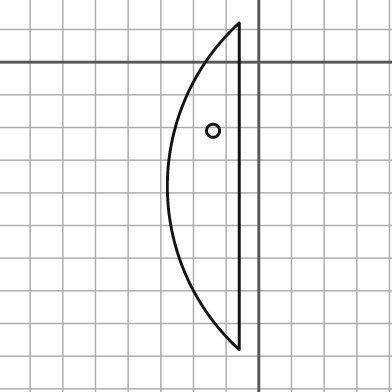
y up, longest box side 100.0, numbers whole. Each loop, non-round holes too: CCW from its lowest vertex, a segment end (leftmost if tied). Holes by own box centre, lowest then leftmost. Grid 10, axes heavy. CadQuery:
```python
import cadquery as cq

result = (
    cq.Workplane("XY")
    .moveTo(-6.0, -88.0)
    .lineTo(-6.0, 12.0)
    .threePointArc((-28.0, -38.0), (-6.0, -88.0))
    .close()
    .moveTo(-14.0, -21.0)
    .circle(2.0)
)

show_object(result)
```